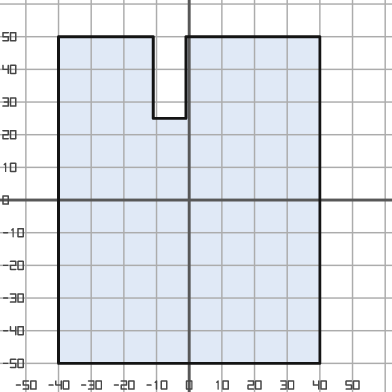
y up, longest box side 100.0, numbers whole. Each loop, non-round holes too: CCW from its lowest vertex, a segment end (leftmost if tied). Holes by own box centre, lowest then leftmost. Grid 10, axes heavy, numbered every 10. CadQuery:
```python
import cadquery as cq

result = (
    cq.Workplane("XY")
    .moveTo(-40.0, -50.0)
    .lineTo(40.0, -50.0)
    .lineTo(40.0, 50.0)
    .lineTo(-1.0, 50.0)
    .lineTo(-1.0, 25.0)
    .lineTo(-11.0, 25.0)
    .lineTo(-11.0, 50.0)
    .lineTo(-40.0, 50.0)
    .close()
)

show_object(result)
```